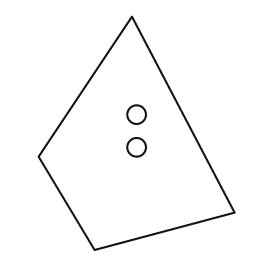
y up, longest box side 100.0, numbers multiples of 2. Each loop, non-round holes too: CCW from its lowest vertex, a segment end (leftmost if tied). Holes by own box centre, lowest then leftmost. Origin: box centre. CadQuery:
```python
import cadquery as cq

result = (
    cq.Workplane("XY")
    .moveTo(-18.0, -50.0)
    .lineTo(42.0, -34.0)
    .lineTo(-2.0, 50.0)
    .lineTo(-42.0, -10.0)
    .close()
    .moveTo(0.0, -6.0)
    .circle(4.0)
    .moveTo(0.0, 8.0)
    .circle(4.0)
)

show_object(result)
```